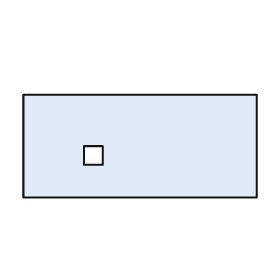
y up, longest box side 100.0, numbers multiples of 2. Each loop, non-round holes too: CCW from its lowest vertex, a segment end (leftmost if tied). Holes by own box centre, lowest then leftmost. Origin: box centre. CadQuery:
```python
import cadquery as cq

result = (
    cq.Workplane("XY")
    .moveTo(-50.0, -22.0)
    .lineTo(50.0, -22.0)
    .lineTo(50.0, 22.0)
    .lineTo(-50.0, 22.0)
    .close()
    .moveTo(-24.0, -8.0)
    .lineTo(-16.0, -8.0)
    .lineTo(-16.0, 0.0)
    .lineTo(-24.0, 0.0)
    .close()
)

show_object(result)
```